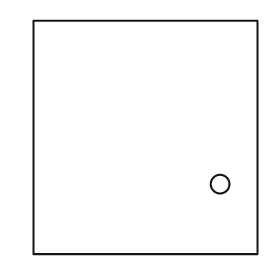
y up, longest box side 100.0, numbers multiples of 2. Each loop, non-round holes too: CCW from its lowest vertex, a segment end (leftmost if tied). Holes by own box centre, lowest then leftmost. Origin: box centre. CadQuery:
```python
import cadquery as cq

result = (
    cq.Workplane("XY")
    .moveTo(-48.0, -50.0)
    .lineTo(48.0, -50.0)
    .lineTo(48.0, 50.0)
    .lineTo(-48.0, 50.0)
    .close()
    .moveTo(32.0, -20.0)
    .circle(4.0)
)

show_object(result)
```